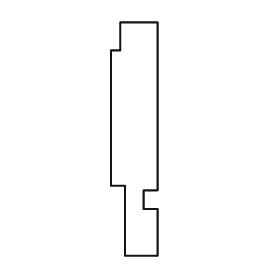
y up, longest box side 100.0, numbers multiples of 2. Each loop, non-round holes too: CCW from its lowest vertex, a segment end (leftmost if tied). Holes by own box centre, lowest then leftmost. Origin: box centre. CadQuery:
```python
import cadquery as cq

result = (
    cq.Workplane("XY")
    .moveTo(-4.0, -50.0)
    .lineTo(10.0, -50.0)
    .lineTo(10.0, -30.0)
    .lineTo(4.0, -30.0)
    .lineTo(4.0, -22.0)
    .lineTo(10.0, -22.0)
    .lineTo(10.0, 50.0)
    .lineTo(-6.0, 50.0)
    .lineTo(-6.0, 38.0)
    .lineTo(-10.0, 38.0)
    .lineTo(-10.0, -20.0)
    .lineTo(-4.0, -20.0)
    .close()
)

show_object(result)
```